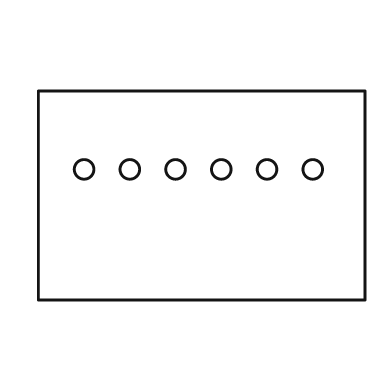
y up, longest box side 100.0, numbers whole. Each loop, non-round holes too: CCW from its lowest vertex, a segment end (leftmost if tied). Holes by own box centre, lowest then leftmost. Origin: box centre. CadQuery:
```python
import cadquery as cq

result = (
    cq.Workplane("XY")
    .moveTo(-50.0, -32.0)
    .lineTo(50.0, -32.0)
    .lineTo(50.0, 32.0)
    .lineTo(-50.0, 32.0)
    .close()
    .moveTo(-36.0, 8.0)
    .circle(3.0)
    .moveTo(-22.0, 8.0)
    .circle(3.0)
    .moveTo(-8.0, 8.0)
    .circle(3.0)
    .moveTo(6.0, 8.0)
    .circle(3.0)
    .moveTo(20.0, 8.0)
    .circle(3.0)
    .moveTo(34.0, 8.0)
    .circle(3.0)
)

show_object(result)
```